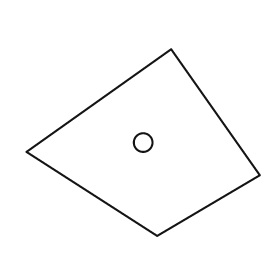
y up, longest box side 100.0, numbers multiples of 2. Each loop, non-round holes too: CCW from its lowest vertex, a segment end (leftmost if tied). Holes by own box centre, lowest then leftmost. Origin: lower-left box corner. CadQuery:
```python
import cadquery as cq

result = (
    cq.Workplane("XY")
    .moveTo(56.0, 0.0)
    .lineTo(100.0, 26.0)
    .lineTo(62.0, 80.0)
    .lineTo(0.0, 36.0)
    .close()
    .moveTo(50.0, 40.0)
    .circle(4.0)
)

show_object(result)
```